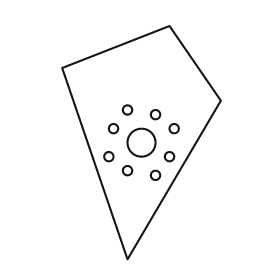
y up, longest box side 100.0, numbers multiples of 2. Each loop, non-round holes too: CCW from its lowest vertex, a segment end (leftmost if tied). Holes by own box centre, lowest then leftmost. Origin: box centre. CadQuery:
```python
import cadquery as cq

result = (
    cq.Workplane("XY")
    .moveTo(-6.0, -50.0)
    .lineTo(34.0, 18.0)
    .lineTo(12.0, 50.0)
    .lineTo(-34.0, 32.0)
    .close()
    .moveTo(6.0, -14.0)
    .circle(2.0)
    .moveTo(-6.0, -12.0)
    .circle(2.0)
    .moveTo(-14.0, -6.0)
    .circle(2.0)
    .moveTo(12.0, -6.0)
    .circle(2.0)
    .moveTo(0.0, 0.0)
    .circle(6.0)
    .moveTo(-12.0, 6.0)
    .circle(2.0)
    .moveTo(14.0, 6.0)
    .circle(2.0)
    .moveTo(6.0, 12.0)
    .circle(2.0)
    .moveTo(-6.0, 14.0)
    .circle(2.0)
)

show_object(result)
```